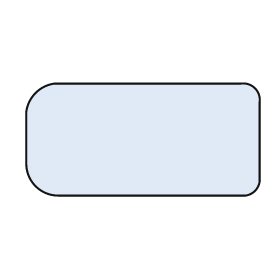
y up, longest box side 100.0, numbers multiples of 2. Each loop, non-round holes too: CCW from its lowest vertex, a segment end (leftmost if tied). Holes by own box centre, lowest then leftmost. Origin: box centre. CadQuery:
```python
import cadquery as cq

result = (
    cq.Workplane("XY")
    .moveTo(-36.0, -24.0)
    .lineTo(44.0, -24.0)
    .threePointArc((48.0, -22.0), (50.0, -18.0))
    .lineTo(50.0, 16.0)
    .threePointArc((48.0, 22.0), (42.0, 24.0))
    .lineTo(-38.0, 24.0)
    .threePointArc((-46.0, 20.0), (-50.0, 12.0))
    .lineTo(-50.0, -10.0)
    .threePointArc((-46.0, -20.0), (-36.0, -24.0))
    .close()
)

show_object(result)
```